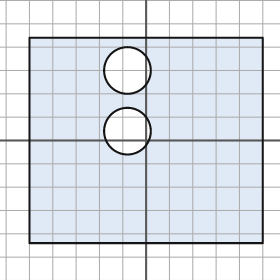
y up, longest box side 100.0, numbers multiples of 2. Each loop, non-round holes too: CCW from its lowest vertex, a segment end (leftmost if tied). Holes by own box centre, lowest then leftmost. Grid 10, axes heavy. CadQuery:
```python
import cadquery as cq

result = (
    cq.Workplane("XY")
    .moveTo(-50.0, -44.0)
    .lineTo(50.0, -44.0)
    .lineTo(50.0, 44.0)
    .lineTo(-50.0, 44.0)
    .close()
    .moveTo(-8.0, 4.0)
    .circle(10.0)
    .moveTo(-8.0, 30.0)
    .circle(10.0)
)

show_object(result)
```